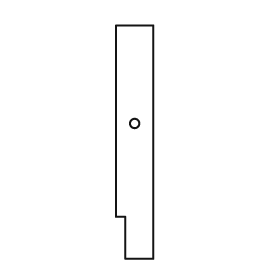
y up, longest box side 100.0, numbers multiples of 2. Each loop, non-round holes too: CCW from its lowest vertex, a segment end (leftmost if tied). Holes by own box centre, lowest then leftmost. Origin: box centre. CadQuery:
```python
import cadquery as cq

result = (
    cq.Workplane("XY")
    .moveTo(-4.0, -50.0)
    .lineTo(8.0, -50.0)
    .lineTo(8.0, 50.0)
    .lineTo(-8.0, 50.0)
    .lineTo(-8.0, -32.0)
    .lineTo(-4.0, -32.0)
    .close()
    .moveTo(0.0, 8.0)
    .circle(2.0)
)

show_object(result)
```